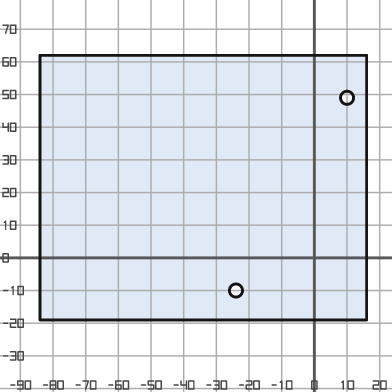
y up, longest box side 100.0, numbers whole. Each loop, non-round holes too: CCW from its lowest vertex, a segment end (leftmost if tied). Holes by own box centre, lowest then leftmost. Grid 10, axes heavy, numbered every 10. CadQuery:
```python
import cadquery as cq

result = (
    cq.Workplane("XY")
    .moveTo(-84.0, -19.0)
    .lineTo(16.0, -19.0)
    .lineTo(16.0, 62.0)
    .lineTo(-84.0, 62.0)
    .close()
    .moveTo(-24.0, -10.0)
    .circle(2.0)
    .moveTo(10.0, 49.0)
    .circle(2.0)
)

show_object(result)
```